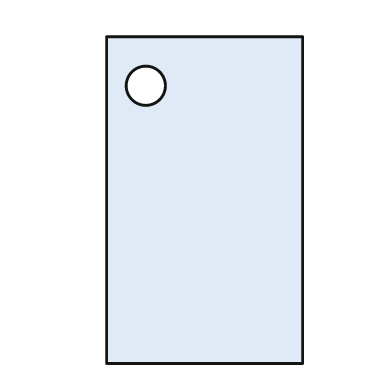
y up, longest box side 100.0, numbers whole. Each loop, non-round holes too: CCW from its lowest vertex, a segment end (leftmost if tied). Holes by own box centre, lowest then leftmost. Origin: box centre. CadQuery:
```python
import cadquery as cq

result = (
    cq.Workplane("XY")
    .moveTo(-30.0, -50.0)
    .lineTo(30.0, -50.0)
    .lineTo(30.0, 50.0)
    .lineTo(-30.0, 50.0)
    .close()
    .moveTo(-18.0, 35.0)
    .circle(6.0)
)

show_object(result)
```